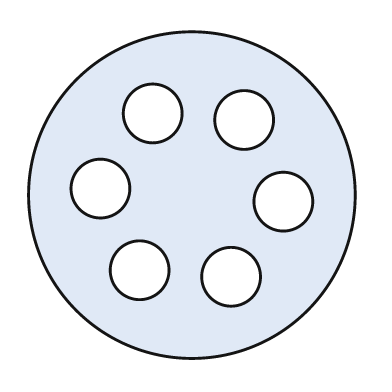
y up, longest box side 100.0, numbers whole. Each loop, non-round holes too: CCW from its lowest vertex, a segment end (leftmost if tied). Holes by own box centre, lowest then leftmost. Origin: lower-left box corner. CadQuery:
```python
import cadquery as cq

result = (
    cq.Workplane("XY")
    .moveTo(50.0, 50.0)
    .circle(50.0)
    .moveTo(62.0, 25.0)
    .circle(9.0)
    .moveTo(34.0, 27.0)
    .circle(9.0)
    .moveTo(78.0, 48.0)
    .circle(9.0)
    .moveTo(22.0, 52.0)
    .circle(9.0)
    .moveTo(66.0, 73.0)
    .circle(9.0)
    .moveTo(38.0, 75.0)
    .circle(9.0)
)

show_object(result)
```